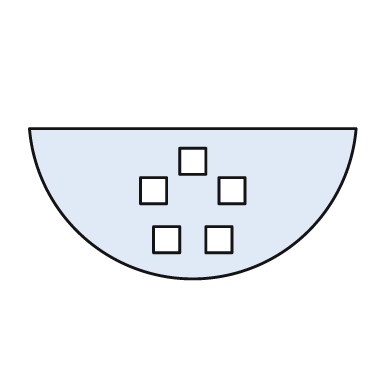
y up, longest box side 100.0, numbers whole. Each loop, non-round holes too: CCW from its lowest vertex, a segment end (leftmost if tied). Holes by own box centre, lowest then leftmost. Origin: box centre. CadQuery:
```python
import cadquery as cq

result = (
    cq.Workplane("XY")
    .moveTo(-50.0, 23.0)
    .threePointArc((0.0, -23.0), (50.0, 23.0))
    .close()
    .moveTo(-12.0, -15.0)
    .lineTo(-4.0, -15.0)
    .lineTo(-4.0, -7.0)
    .lineTo(-12.0, -7.0)
    .close()
    .moveTo(4.0, -15.0)
    .lineTo(12.0, -15.0)
    .lineTo(12.0, -7.0)
    .lineTo(4.0, -7.0)
    .close()
    .moveTo(-16.0, 0.0)
    .lineTo(-8.0, 0.0)
    .lineTo(-8.0, 8.0)
    .lineTo(-16.0, 8.0)
    .close()
    .moveTo(8.0, 0.0)
    .lineTo(16.0, 0.0)
    .lineTo(16.0, 8.0)
    .lineTo(8.0, 8.0)
    .close()
    .moveTo(-4.0, 9.0)
    .lineTo(4.0, 9.0)
    .lineTo(4.0, 17.0)
    .lineTo(-4.0, 17.0)
    .close()
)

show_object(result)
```